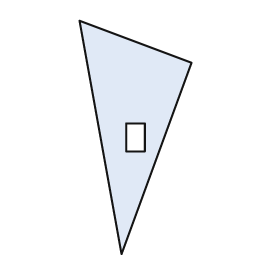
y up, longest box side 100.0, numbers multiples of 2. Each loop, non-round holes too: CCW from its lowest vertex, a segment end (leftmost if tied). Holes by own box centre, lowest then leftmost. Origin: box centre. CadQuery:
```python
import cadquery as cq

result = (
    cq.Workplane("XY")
    .moveTo(-6.0, -50.0)
    .lineTo(24.0, 32.0)
    .lineTo(-24.0, 50.0)
    .close()
    .moveTo(-4.0, -6.0)
    .lineTo(4.0, -6.0)
    .lineTo(4.0, 6.0)
    .lineTo(-4.0, 6.0)
    .close()
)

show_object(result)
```